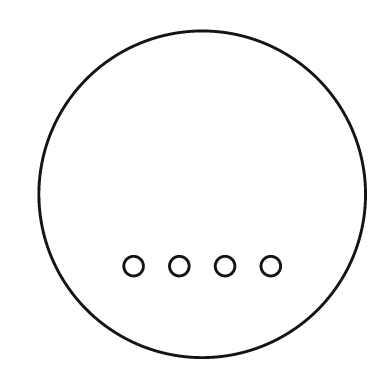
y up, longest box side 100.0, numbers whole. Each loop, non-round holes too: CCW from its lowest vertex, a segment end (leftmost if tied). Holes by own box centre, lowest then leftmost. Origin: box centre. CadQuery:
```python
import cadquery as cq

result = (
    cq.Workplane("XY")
    .moveTo(0.0, 0.0)
    .circle(50.0)
    .moveTo(-21.0, -22.0)
    .circle(3.0)
    .moveTo(-7.0, -22.0)
    .circle(3.0)
    .moveTo(7.0, -22.0)
    .circle(3.0)
    .moveTo(21.0, -22.0)
    .circle(3.0)
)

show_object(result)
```